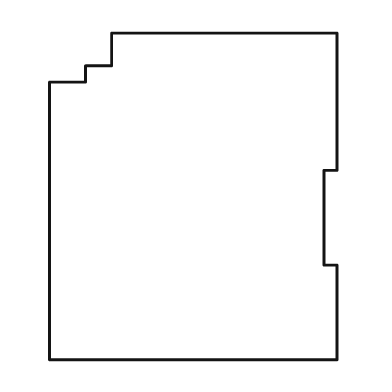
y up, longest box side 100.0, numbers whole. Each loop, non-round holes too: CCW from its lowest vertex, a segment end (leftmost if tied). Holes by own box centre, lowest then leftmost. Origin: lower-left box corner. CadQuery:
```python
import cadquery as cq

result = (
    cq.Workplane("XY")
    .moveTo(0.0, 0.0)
    .lineTo(88.0, 0.0)
    .lineTo(88.0, 29.0)
    .lineTo(84.0, 29.0)
    .lineTo(84.0, 58.0)
    .lineTo(88.0, 58.0)
    .lineTo(88.0, 100.0)
    .lineTo(19.0, 100.0)
    .lineTo(19.0, 90.0)
    .lineTo(11.0, 90.0)
    .lineTo(11.0, 85.0)
    .lineTo(0.0, 85.0)
    .close()
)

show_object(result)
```